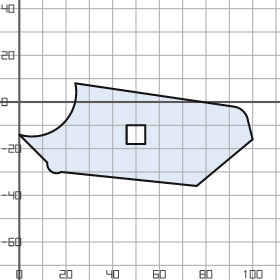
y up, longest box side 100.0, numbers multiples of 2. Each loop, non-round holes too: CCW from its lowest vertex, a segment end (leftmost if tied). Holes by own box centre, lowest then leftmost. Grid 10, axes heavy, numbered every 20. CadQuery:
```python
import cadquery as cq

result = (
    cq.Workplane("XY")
    .moveTo(76.0, -36.0)
    .lineTo(100.0, -16.0)
    .lineTo(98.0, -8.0)
    .threePointArc((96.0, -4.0), (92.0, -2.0))
    .lineTo(24.0, 8.0)
    .threePointArc((18.0, -10.0), (0.0, -14.0))
    .lineTo(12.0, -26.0)
    .threePointArc((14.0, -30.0), (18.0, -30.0))
    .close()
    .moveTo(46.0, -18.0)
    .lineTo(54.0, -18.0)
    .lineTo(54.0, -10.0)
    .lineTo(46.0, -10.0)
    .close()
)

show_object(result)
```